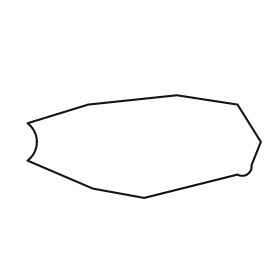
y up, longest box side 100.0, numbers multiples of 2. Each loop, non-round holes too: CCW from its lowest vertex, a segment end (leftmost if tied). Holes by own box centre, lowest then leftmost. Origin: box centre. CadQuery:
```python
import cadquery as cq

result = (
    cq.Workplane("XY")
    .moveTo(0.0, -22.0)
    .lineTo(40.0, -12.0)
    .threePointArc((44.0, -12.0), (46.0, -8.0))
    .lineTo(50.0, 2.0)
    .lineTo(40.0, 18.0)
    .lineTo(14.0, 22.0)
    .lineTo(-24.0, 18.0)
    .lineTo(-50.0, 10.0)
    .threePointArc((-46.0, 2.0), (-50.0, -6.0))
    .lineTo(-22.0, -18.0)
    .close()
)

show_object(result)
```